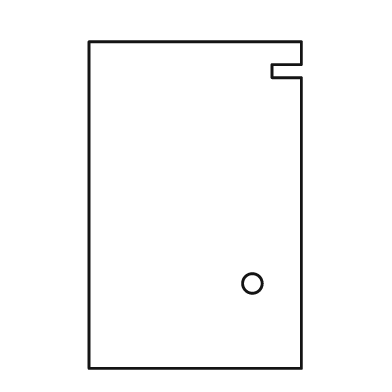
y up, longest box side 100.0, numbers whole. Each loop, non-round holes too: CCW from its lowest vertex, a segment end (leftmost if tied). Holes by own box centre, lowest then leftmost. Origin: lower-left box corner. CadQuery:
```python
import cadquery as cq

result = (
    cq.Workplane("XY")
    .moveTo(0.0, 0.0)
    .lineTo(65.0, 0.0)
    .lineTo(65.0, 89.0)
    .lineTo(56.0, 89.0)
    .lineTo(56.0, 93.0)
    .lineTo(65.0, 93.0)
    .lineTo(65.0, 100.0)
    .lineTo(0.0, 100.0)
    .close()
    .moveTo(50.0, 26.0)
    .circle(3.0)
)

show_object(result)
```